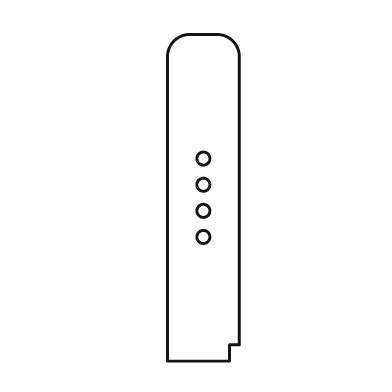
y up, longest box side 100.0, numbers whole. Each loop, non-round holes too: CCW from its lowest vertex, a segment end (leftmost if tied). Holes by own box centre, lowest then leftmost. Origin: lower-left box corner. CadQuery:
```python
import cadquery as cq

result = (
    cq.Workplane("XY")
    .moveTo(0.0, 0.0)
    .lineTo(19.0, 0.0)
    .lineTo(19.0, 5.0)
    .lineTo(22.0, 5.0)
    .lineTo(22.0, 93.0)
    .threePointArc((20.0, 98.0), (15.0, 100.0))
    .lineTo(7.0, 100.0)
    .threePointArc((2.0, 98.0), (0.0, 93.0))
    .close()
    .moveTo(11.0, 38.0)
    .circle(2.0)
    .moveTo(11.0, 46.0)
    .circle(2.0)
    .moveTo(11.0, 54.0)
    .circle(2.0)
    .moveTo(11.0, 62.0)
    .circle(2.0)
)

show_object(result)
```